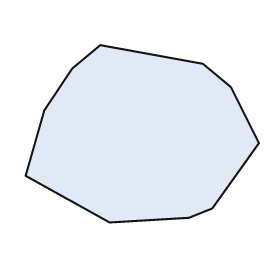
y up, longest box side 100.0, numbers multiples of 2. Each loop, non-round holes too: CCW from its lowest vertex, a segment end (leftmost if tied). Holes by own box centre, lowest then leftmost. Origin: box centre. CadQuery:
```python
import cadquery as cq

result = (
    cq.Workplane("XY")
    .moveTo(-14.0, -38.0)
    .lineTo(20.0, -36.0)
    .lineTo(30.0, -32.0)
    .lineTo(50.0, -4.0)
    .lineTo(38.0, 20.0)
    .lineTo(26.0, 30.0)
    .lineTo(-18.0, 38.0)
    .lineTo(-30.0, 28.0)
    .lineTo(-42.0, 10.0)
    .lineTo(-50.0, -18.0)
    .close()
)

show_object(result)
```